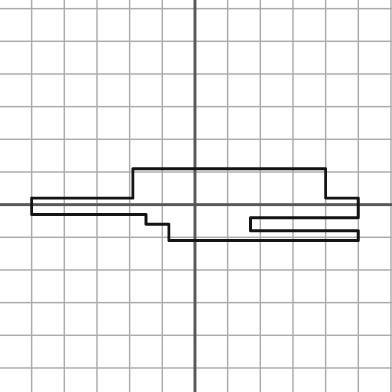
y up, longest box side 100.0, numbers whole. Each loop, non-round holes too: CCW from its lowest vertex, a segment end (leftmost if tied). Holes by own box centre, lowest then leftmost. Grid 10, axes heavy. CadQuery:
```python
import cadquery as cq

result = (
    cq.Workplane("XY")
    .moveTo(-8.0, -11.0)
    .lineTo(50.0, -11.0)
    .lineTo(50.0, -8.0)
    .lineTo(17.0, -8.0)
    .lineTo(17.0, -4.0)
    .lineTo(50.0, -4.0)
    .lineTo(50.0, 2.0)
    .lineTo(40.0, 2.0)
    .lineTo(40.0, 11.0)
    .lineTo(-19.0, 11.0)
    .lineTo(-19.0, 2.0)
    .lineTo(-50.0, 2.0)
    .lineTo(-50.0, -3.0)
    .lineTo(-15.0, -3.0)
    .lineTo(-15.0, -6.0)
    .lineTo(-8.0, -6.0)
    .close()
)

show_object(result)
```